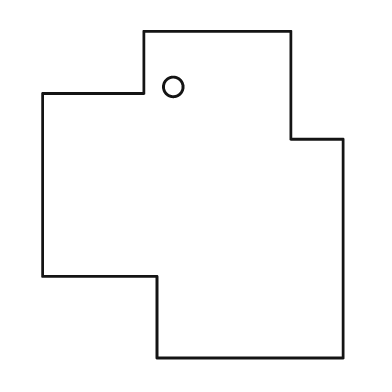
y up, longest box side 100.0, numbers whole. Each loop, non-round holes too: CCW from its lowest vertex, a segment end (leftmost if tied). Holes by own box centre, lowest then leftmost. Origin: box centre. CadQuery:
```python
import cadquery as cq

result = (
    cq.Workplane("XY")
    .moveTo(-11.0, -50.0)
    .lineTo(46.0, -50.0)
    .lineTo(46.0, 17.0)
    .lineTo(30.0, 17.0)
    .lineTo(30.0, 50.0)
    .lineTo(-15.0, 50.0)
    .lineTo(-15.0, 31.0)
    .lineTo(-46.0, 31.0)
    .lineTo(-46.0, -25.0)
    .lineTo(-11.0, -25.0)
    .close()
    .moveTo(-6.0, 33.0)
    .circle(3.0)
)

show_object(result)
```